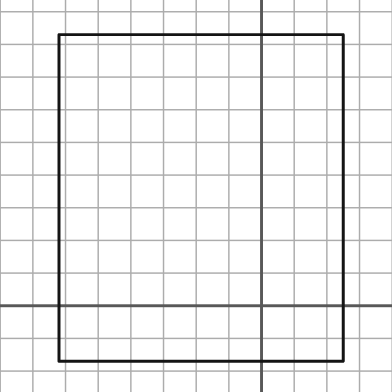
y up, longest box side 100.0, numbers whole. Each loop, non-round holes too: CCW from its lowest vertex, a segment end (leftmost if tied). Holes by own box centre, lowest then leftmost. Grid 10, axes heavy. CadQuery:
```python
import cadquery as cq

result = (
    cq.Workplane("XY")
    .moveTo(-62.0, -17.0)
    .lineTo(25.0, -17.0)
    .lineTo(25.0, 83.0)
    .lineTo(-62.0, 83.0)
    .close()
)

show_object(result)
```